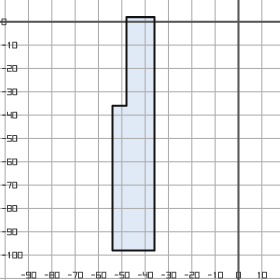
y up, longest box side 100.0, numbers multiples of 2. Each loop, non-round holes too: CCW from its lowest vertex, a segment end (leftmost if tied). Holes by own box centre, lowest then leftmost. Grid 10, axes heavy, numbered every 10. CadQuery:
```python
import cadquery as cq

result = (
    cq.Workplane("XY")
    .moveTo(-54.0, -98.0)
    .lineTo(-36.0, -98.0)
    .lineTo(-36.0, 2.0)
    .lineTo(-48.0, 2.0)
    .lineTo(-48.0, -36.0)
    .lineTo(-54.0, -36.0)
    .close()
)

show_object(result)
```